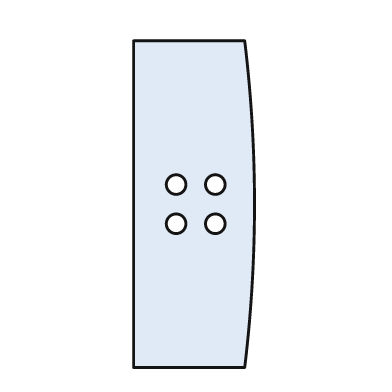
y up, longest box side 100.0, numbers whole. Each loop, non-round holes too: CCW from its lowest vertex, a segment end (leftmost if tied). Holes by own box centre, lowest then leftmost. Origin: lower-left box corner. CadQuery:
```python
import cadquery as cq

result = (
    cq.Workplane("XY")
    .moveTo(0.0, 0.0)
    .lineTo(34.0, 0.0)
    .threePointArc((37.0, 50.0), (34.0, 100.0))
    .lineTo(0.0, 100.0)
    .close()
    .moveTo(13.0, 44.0)
    .circle(3.0)
    .moveTo(25.0, 44.0)
    .circle(3.0)
    .moveTo(13.0, 56.0)
    .circle(3.0)
    .moveTo(25.0, 56.0)
    .circle(3.0)
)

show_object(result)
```